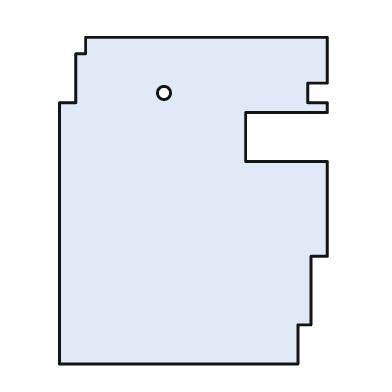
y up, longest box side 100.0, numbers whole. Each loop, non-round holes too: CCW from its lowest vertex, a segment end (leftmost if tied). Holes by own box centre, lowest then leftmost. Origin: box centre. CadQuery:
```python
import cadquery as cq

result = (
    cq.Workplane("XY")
    .moveTo(-41.0, -50.0)
    .lineTo(32.0, -50.0)
    .lineTo(32.0, -38.0)
    .lineTo(36.0, -38.0)
    .lineTo(36.0, -17.0)
    .lineTo(41.0, -17.0)
    .lineTo(41.0, 12.0)
    .lineTo(16.0, 12.0)
    .lineTo(16.0, 27.0)
    .lineTo(41.0, 27.0)
    .lineTo(41.0, 30.0)
    .lineTo(35.0, 30.0)
    .lineTo(35.0, 36.0)
    .lineTo(41.0, 36.0)
    .lineTo(41.0, 50.0)
    .lineTo(-33.0, 50.0)
    .lineTo(-33.0, 45.0)
    .lineTo(-36.0, 45.0)
    .lineTo(-36.0, 30.0)
    .lineTo(-41.0, 30.0)
    .close()
    .moveTo(-9.0, 33.0)
    .circle(2.0)
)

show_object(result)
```